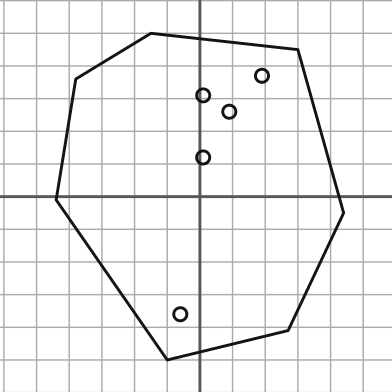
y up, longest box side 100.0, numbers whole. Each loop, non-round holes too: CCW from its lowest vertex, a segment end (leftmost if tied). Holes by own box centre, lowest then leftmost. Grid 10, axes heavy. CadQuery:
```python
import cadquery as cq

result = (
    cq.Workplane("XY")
    .moveTo(-10.0, -50.0)
    .lineTo(27.0, -41.0)
    .lineTo(44.0, -5.0)
    .lineTo(30.0, 45.0)
    .lineTo(-15.0, 50.0)
    .lineTo(-38.0, 36.0)
    .lineTo(-44.0, -1.0)
    .close()
    .moveTo(-6.0, -36.0)
    .circle(2.0)
    .moveTo(1.0, 12.0)
    .circle(2.0)
    .moveTo(9.0, 26.0)
    .circle(2.0)
    .moveTo(1.0, 31.0)
    .circle(2.0)
    .moveTo(19.0, 37.0)
    .circle(2.0)
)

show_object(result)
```